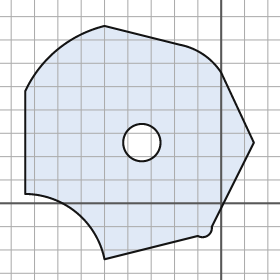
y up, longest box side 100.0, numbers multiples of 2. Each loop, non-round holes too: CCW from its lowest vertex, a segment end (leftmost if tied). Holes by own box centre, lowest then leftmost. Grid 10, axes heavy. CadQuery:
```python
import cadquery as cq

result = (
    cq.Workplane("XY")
    .moveTo(-50.0, -24.0)
    .lineTo(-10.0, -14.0)
    .threePointArc((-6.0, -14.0), (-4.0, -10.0))
    .lineTo(14.0, 26.0)
    .lineTo(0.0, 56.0)
    .threePointArc((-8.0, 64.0), (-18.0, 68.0))
    .lineTo(-50.0, 76.0)
    .threePointArc((-70.0, 66.0), (-84.0, 48.0))
    .lineTo(-84.0, 4.0)
    .threePointArc((-62.0, -4.0), (-50.0, -24.0))
    .close()
    .moveTo(-34.0, 26.0)
    .circle(8.0)
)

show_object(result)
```